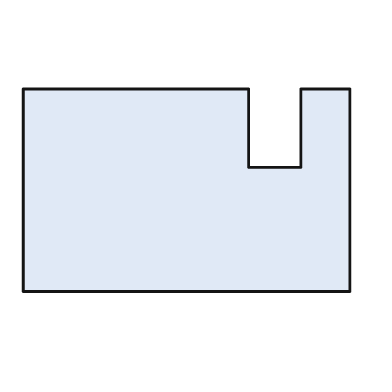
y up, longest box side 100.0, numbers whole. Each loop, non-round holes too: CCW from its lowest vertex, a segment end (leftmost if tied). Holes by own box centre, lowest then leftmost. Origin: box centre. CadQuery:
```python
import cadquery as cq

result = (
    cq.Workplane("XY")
    .moveTo(-50.0, -31.0)
    .lineTo(50.0, -31.0)
    .lineTo(50.0, 31.0)
    .lineTo(35.0, 31.0)
    .lineTo(35.0, 7.0)
    .lineTo(19.0, 7.0)
    .lineTo(19.0, 31.0)
    .lineTo(-50.0, 31.0)
    .close()
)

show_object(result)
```